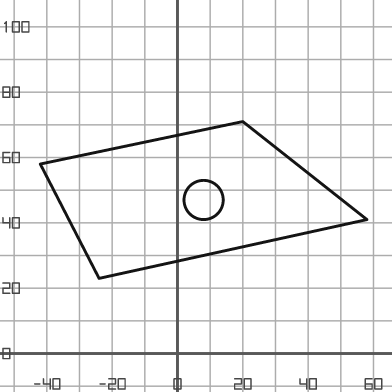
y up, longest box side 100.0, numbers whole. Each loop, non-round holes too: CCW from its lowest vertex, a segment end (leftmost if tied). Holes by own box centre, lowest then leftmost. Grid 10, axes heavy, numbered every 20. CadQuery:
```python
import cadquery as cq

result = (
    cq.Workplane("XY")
    .moveTo(-24.0, 23.0)
    .lineTo(58.0, 41.0)
    .lineTo(20.0, 71.0)
    .lineTo(-42.0, 58.0)
    .close()
    .moveTo(8.0, 47.0)
    .circle(6.0)
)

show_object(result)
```